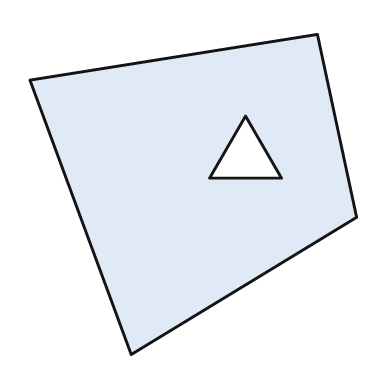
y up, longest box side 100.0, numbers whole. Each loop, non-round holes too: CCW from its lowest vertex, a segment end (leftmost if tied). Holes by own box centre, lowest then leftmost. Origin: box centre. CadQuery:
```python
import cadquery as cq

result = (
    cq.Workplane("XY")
    .moveTo(-19.0, -49.0)
    .lineTo(50.0, -7.0)
    .lineTo(38.0, 49.0)
    .lineTo(-50.0, 35.0)
    .close()
    .moveTo(5.0, 5.0)
    .lineTo(27.0, 5.0)
    .lineTo(16.0, 24.0)
    .close()
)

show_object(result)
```